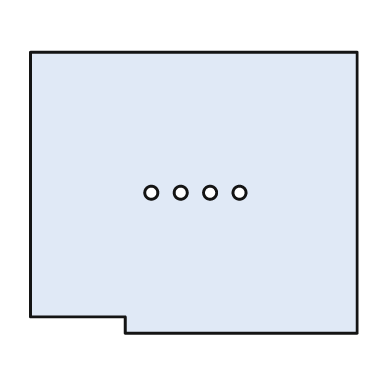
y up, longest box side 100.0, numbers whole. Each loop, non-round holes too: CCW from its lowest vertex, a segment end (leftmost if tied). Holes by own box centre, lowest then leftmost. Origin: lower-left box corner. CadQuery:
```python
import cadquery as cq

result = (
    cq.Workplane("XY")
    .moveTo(29.0, 0.0)
    .lineTo(100.0, 0.0)
    .lineTo(100.0, 86.0)
    .lineTo(0.0, 86.0)
    .lineTo(0.0, 5.0)
    .lineTo(29.0, 5.0)
    .close()
    .moveTo(37.0, 43.0)
    .circle(2.0)
    .moveTo(46.0, 43.0)
    .circle(2.0)
    .moveTo(55.0, 43.0)
    .circle(2.0)
    .moveTo(64.0, 43.0)
    .circle(2.0)
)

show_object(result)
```